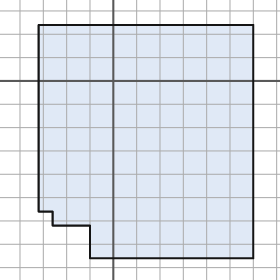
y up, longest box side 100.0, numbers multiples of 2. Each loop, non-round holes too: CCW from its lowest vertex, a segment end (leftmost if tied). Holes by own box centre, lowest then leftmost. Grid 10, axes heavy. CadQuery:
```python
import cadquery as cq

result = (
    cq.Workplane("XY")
    .moveTo(-10.0, -76.0)
    .lineTo(60.0, -76.0)
    .lineTo(60.0, 24.0)
    .lineTo(-32.0, 24.0)
    .lineTo(-32.0, -56.0)
    .lineTo(-26.0, -56.0)
    .lineTo(-26.0, -62.0)
    .lineTo(-10.0, -62.0)
    .close()
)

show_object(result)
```